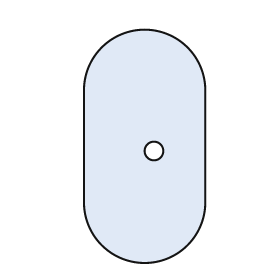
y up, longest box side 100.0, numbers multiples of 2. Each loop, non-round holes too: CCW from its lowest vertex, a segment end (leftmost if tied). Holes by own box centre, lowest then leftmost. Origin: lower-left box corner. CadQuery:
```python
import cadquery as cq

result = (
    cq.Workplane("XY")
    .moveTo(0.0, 26.0)
    .threePointArc((26.0, 0.0), (52.0, 26.0))
    .lineTo(52.0, 74.0)
    .threePointArc((26.0, 100.0), (0.0, 74.0))
    .close()
    .moveTo(30.0, 48.0)
    .circle(4.0)
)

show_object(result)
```